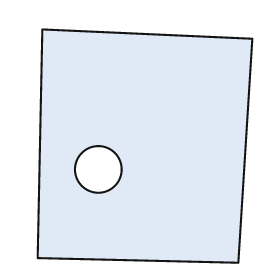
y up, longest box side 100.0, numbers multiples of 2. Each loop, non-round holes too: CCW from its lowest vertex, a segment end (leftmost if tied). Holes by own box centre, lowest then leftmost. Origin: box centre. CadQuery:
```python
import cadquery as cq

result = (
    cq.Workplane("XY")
    .moveTo(40.0, -50.0)
    .lineTo(46.0, 46.0)
    .lineTo(-44.0, 50.0)
    .lineTo(-46.0, -48.0)
    .close()
    .moveTo(-20.0, -10.0)
    .circle(10.0)
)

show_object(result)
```